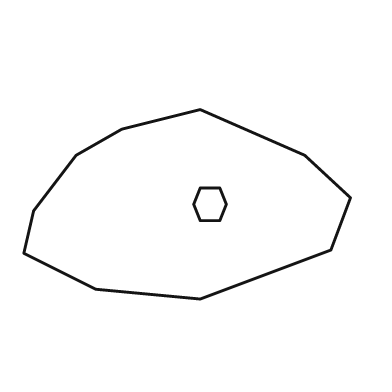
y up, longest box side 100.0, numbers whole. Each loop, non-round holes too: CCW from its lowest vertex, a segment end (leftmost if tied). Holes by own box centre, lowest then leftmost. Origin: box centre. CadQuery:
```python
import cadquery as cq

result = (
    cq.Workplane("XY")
    .moveTo(4.0, -29.0)
    .lineTo(44.0, -14.0)
    .lineTo(50.0, 2.0)
    .lineTo(36.0, 15.0)
    .lineTo(4.0, 29.0)
    .lineTo(-20.0, 23.0)
    .lineTo(-34.0, 15.0)
    .lineTo(-47.0, -2.0)
    .lineTo(-50.0, -15.0)
    .lineTo(-28.0, -26.0)
    .close()
    .moveTo(4.0, -5.0)
    .lineTo(10.0, -5.0)
    .lineTo(12.0, 0.0)
    .lineTo(10.0, 5.0)
    .lineTo(4.0, 5.0)
    .lineTo(2.0, 0.0)
    .close()
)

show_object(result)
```